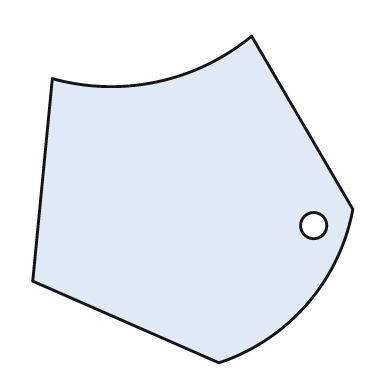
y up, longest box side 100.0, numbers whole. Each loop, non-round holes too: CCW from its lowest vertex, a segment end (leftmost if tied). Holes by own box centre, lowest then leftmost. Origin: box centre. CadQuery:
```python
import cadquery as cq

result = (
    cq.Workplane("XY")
    .moveTo(8.0, -50.0)
    .threePointArc((35.0, -32.0), (49.0, -3.0))
    .lineTo(18.0, 50.0)
    .threePointArc((-11.0, 36.0), (-43.0, 37.0))
    .lineTo(-49.0, -25.0)
    .close()
    .moveTo(37.0, -8.0)
    .circle(4.0)
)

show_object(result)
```